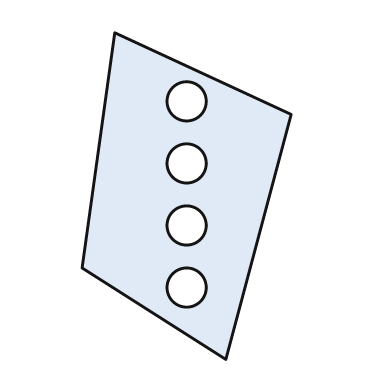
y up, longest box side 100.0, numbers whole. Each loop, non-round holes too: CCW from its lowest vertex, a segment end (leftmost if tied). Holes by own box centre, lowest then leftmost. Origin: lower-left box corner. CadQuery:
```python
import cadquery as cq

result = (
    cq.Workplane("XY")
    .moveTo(44.0, 0.0)
    .lineTo(64.0, 75.0)
    .lineTo(10.0, 100.0)
    .lineTo(0.0, 28.0)
    .close()
    .moveTo(32.0, 22.0)
    .circle(6.0)
    .moveTo(32.0, 41.0)
    .circle(6.0)
    .moveTo(32.0, 60.0)
    .circle(6.0)
    .moveTo(32.0, 79.0)
    .circle(6.0)
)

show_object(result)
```